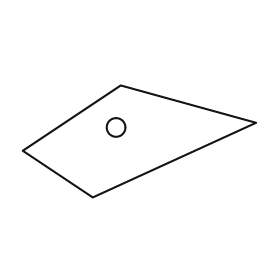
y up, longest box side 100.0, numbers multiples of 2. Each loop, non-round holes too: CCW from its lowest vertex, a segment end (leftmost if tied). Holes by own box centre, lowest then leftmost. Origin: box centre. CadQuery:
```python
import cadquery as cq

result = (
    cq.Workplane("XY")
    .moveTo(-20.0, -24.0)
    .lineTo(50.0, 8.0)
    .lineTo(-8.0, 24.0)
    .lineTo(-50.0, -4.0)
    .close()
    .moveTo(-10.0, 6.0)
    .circle(4.0)
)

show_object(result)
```